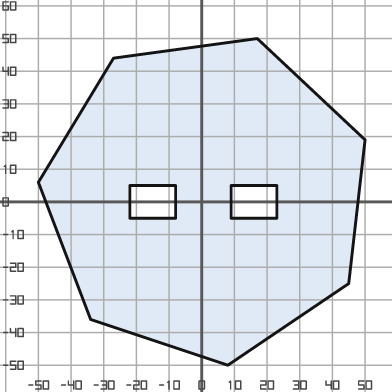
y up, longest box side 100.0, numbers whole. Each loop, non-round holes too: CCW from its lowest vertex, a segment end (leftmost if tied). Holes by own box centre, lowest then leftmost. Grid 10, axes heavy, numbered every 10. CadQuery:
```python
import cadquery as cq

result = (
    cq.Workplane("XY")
    .moveTo(8.0, -50.0)
    .lineTo(45.0, -25.0)
    .lineTo(50.0, 19.0)
    .lineTo(17.0, 50.0)
    .lineTo(-27.0, 44.0)
    .lineTo(-50.0, 6.0)
    .lineTo(-34.0, -36.0)
    .close()
    .moveTo(-22.0, -5.0)
    .lineTo(-8.0, -5.0)
    .lineTo(-8.0, 5.0)
    .lineTo(-22.0, 5.0)
    .close()
    .moveTo(9.0, -5.0)
    .lineTo(23.0, -5.0)
    .lineTo(23.0, 5.0)
    .lineTo(9.0, 5.0)
    .close()
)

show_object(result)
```